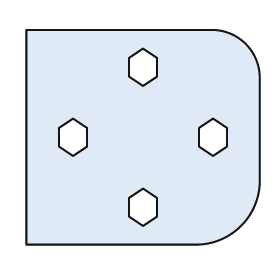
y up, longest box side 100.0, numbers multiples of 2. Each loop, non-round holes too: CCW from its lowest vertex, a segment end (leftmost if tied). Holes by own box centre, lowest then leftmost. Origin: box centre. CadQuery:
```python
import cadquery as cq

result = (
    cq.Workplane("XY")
    .moveTo(-50.0, -46.0)
    .lineTo(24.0, -46.0)
    .threePointArc((42.0, -38.0), (50.0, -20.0))
    .lineTo(50.0, 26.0)
    .threePointArc((44.0, 40.0), (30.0, 46.0))
    .lineTo(-50.0, 46.0)
    .close()
    .moveTo(0.0, -38.0)
    .lineTo(6.0, -34.0)
    .lineTo(6.0, -26.0)
    .lineTo(0.0, -22.0)
    .lineTo(-6.0, -26.0)
    .lineTo(-6.0, -34.0)
    .close()
    .moveTo(-30.0, -8.0)
    .lineTo(-24.0, -4.0)
    .lineTo(-24.0, 4.0)
    .lineTo(-30.0, 8.0)
    .lineTo(-36.0, 4.0)
    .lineTo(-36.0, -4.0)
    .close()
    .moveTo(30.0, -8.0)
    .lineTo(36.0, -4.0)
    .lineTo(36.0, 4.0)
    .lineTo(30.0, 8.0)
    .lineTo(24.0, 4.0)
    .lineTo(24.0, -4.0)
    .close()
    .moveTo(0.0, 22.0)
    .lineTo(6.0, 26.0)
    .lineTo(6.0, 34.0)
    .lineTo(0.0, 38.0)
    .lineTo(-6.0, 34.0)
    .lineTo(-6.0, 26.0)
    .close()
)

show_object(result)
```